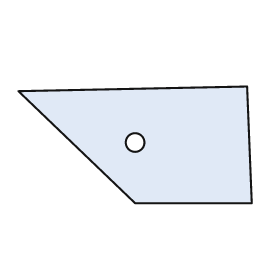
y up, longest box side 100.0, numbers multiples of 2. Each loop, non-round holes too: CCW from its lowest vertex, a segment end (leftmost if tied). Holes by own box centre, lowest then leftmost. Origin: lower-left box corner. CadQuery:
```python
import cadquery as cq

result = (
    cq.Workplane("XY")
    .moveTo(50.0, 0.0)
    .lineTo(100.0, 0.0)
    .lineTo(98.0, 50.0)
    .lineTo(0.0, 48.0)
    .close()
    .moveTo(50.0, 26.0)
    .circle(4.0)
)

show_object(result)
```